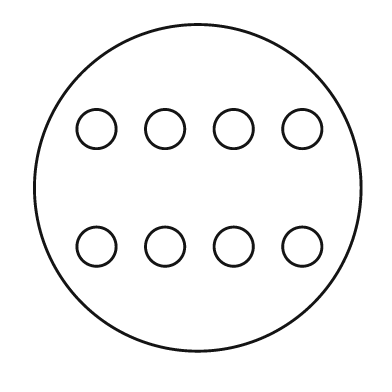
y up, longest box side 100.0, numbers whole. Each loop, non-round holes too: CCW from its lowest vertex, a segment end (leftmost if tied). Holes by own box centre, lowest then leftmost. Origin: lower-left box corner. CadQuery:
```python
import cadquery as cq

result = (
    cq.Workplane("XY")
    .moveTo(50.0, 50.0)
    .circle(50.0)
    .moveTo(19.0, 32.0)
    .circle(6.0)
    .moveTo(40.0, 32.0)
    .circle(6.0)
    .moveTo(61.0, 32.0)
    .circle(6.0)
    .moveTo(82.0, 32.0)
    .circle(6.0)
    .moveTo(19.0, 68.0)
    .circle(6.0)
    .moveTo(40.0, 68.0)
    .circle(6.0)
    .moveTo(61.0, 68.0)
    .circle(6.0)
    .moveTo(82.0, 68.0)
    .circle(6.0)
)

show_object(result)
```